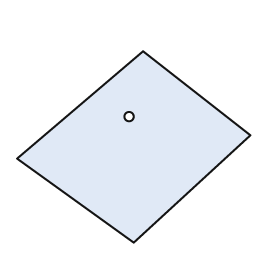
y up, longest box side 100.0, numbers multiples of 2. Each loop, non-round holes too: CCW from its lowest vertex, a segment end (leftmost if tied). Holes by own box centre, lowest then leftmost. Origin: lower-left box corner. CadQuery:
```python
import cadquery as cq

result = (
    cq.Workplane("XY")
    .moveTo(50.0, 0.0)
    .lineTo(100.0, 46.0)
    .lineTo(54.0, 82.0)
    .lineTo(0.0, 36.0)
    .close()
    .moveTo(48.0, 54.0)
    .circle(2.0)
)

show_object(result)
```